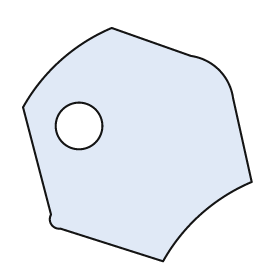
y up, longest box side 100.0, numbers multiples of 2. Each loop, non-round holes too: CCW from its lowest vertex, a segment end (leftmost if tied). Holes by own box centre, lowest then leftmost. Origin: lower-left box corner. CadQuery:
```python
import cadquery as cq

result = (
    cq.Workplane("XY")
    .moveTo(60.0, 0.0)
    .threePointArc((76.0, 20.0), (98.0, 34.0))
    .lineTo(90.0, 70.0)
    .threePointArc((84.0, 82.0), (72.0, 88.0))
    .lineTo(38.0, 100.0)
    .threePointArc((16.0, 86.0), (0.0, 66.0))
    .lineTo(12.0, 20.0)
    .threePointArc((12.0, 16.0), (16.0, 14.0))
    .close()
    .moveTo(24.0, 58.0)
    .circle(10.0)
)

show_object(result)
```